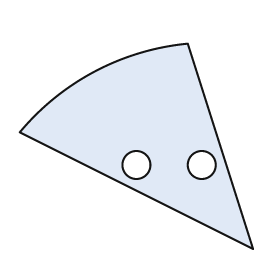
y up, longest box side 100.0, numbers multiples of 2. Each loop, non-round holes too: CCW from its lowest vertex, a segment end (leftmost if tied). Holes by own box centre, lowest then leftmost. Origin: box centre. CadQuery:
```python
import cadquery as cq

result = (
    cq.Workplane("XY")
    .moveTo(50.0, -44.0)
    .lineTo(22.0, 44.0)
    .threePointArc((-18.0, 32.0), (-50.0, 6.0))
    .close()
    .moveTo(0.0, -8.0)
    .circle(6.0)
    .moveTo(28.0, -8.0)
    .circle(6.0)
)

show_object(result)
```